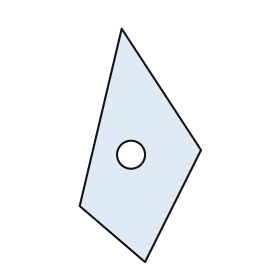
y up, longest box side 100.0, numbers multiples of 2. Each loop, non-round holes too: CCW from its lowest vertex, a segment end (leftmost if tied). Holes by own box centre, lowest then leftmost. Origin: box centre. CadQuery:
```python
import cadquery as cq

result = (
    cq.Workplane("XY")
    .moveTo(2.0, -50.0)
    .lineTo(26.0, -2.0)
    .lineTo(-8.0, 50.0)
    .lineTo(-26.0, -26.0)
    .close()
    .moveTo(-4.0, -4.0)
    .circle(6.0)
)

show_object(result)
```